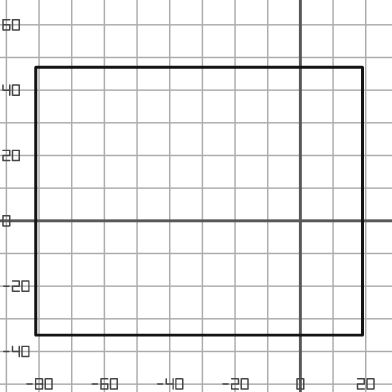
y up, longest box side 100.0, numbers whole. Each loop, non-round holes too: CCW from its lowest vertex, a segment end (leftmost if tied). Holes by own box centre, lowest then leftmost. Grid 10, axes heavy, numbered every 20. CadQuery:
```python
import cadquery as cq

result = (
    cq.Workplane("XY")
    .moveTo(-81.0, -35.0)
    .lineTo(19.0, -35.0)
    .lineTo(19.0, 47.0)
    .lineTo(-81.0, 47.0)
    .close()
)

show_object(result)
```